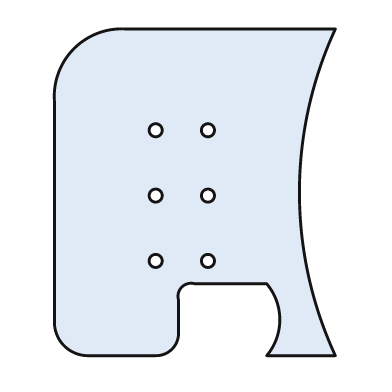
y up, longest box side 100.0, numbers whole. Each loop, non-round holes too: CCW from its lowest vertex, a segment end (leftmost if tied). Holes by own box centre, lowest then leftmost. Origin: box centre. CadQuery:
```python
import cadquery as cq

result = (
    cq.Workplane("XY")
    .moveTo(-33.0, -50.0)
    .lineTo(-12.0, -50.0)
    .threePointArc((-7.0, -48.0), (-5.0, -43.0))
    .lineTo(-5.0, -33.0)
    .threePointArc((-4.0, -29.0), (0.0, -28.0))
    .lineTo(22.0, -28.0)
    .threePointArc((26.0, -39.0), (22.0, -50.0))
    .lineTo(43.0, -50.0)
    .threePointArc((32.0, 0.0), (43.0, 50.0))
    .lineTo(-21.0, 50.0)
    .threePointArc((-37.0, 44.0), (-43.0, 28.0))
    .lineTo(-43.0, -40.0)
    .threePointArc((-40.0, -47.0), (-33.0, -50.0))
    .close()
    .moveTo(-12.0, -21.0)
    .circle(2.0)
    .moveTo(4.0, -21.0)
    .circle(2.0)
    .moveTo(-12.0, -1.0)
    .circle(2.0)
    .moveTo(4.0, -1.0)
    .circle(2.0)
    .moveTo(-12.0, 19.0)
    .circle(2.0)
    .moveTo(4.0, 19.0)
    .circle(2.0)
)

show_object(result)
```